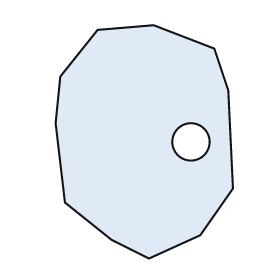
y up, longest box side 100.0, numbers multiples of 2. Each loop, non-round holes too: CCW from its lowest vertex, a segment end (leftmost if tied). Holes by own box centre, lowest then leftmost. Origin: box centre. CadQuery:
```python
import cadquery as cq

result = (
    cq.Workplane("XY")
    .moveTo(2.0, -50.0)
    .lineTo(24.0, -40.0)
    .lineTo(38.0, -20.0)
    .lineTo(36.0, 22.0)
    .lineTo(30.0, 40.0)
    .lineTo(4.0, 50.0)
    .lineTo(-20.0, 48.0)
    .lineTo(-36.0, 28.0)
    .lineTo(-38.0, 8.0)
    .lineTo(-34.0, -26.0)
    .lineTo(-14.0, -42.0)
    .close()
    .moveTo(20.0, 0.0)
    .circle(8.0)
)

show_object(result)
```